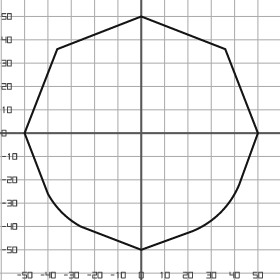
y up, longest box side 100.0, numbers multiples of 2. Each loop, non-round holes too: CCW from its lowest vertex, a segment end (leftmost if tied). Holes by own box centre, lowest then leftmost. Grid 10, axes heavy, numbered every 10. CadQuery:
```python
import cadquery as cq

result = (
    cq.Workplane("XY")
    .moveTo(0.0, -50.0)
    .lineTo(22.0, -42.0)
    .threePointArc((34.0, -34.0), (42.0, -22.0))
    .lineTo(50.0, 0.0)
    .lineTo(36.0, 36.0)
    .lineTo(0.0, 50.0)
    .lineTo(-36.0, 36.0)
    .lineTo(-50.0, 0.0)
    .lineTo(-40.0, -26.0)
    .threePointArc((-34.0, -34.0), (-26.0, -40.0))
    .close()
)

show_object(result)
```